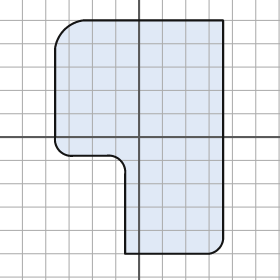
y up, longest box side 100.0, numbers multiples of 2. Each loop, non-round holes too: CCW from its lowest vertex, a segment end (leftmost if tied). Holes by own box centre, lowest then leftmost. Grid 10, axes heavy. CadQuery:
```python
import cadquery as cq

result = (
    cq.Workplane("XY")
    .moveTo(-6.0, -50.0)
    .lineTo(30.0, -50.0)
    .threePointArc((34.0, -48.0), (36.0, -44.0))
    .lineTo(36.0, 50.0)
    .lineTo(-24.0, 50.0)
    .threePointArc((-32.0, 46.0), (-36.0, 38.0))
    .lineTo(-36.0, 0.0)
    .threePointArc((-34.0, -6.0), (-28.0, -8.0))
    .lineTo(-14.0, -8.0)
    .threePointArc((-8.0, -10.0), (-6.0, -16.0))
    .close()
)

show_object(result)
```